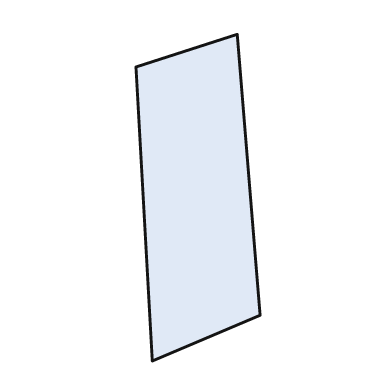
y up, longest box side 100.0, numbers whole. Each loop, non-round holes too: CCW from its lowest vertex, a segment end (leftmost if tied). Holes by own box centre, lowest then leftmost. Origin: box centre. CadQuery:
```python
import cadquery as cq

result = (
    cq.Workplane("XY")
    .moveTo(-14.0, -50.0)
    .lineTo(19.0, -36.0)
    .lineTo(12.0, 50.0)
    .lineTo(-19.0, 40.0)
    .close()
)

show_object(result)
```